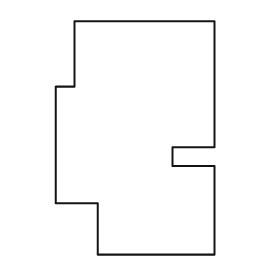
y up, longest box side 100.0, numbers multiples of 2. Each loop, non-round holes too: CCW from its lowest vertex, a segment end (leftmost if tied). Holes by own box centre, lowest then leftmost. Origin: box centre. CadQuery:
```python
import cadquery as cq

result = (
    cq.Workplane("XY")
    .moveTo(-16.0, -50.0)
    .lineTo(34.0, -50.0)
    .lineTo(34.0, -12.0)
    .lineTo(16.0, -12.0)
    .lineTo(16.0, -4.0)
    .lineTo(34.0, -4.0)
    .lineTo(34.0, 50.0)
    .lineTo(-26.0, 50.0)
    .lineTo(-26.0, 22.0)
    .lineTo(-34.0, 22.0)
    .lineTo(-34.0, -28.0)
    .lineTo(-16.0, -28.0)
    .close()
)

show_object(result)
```